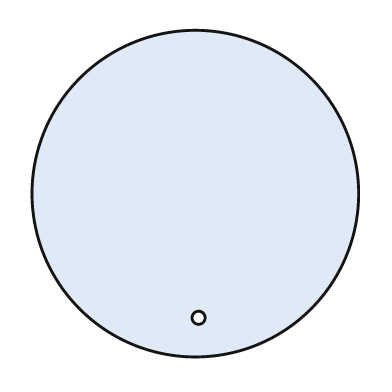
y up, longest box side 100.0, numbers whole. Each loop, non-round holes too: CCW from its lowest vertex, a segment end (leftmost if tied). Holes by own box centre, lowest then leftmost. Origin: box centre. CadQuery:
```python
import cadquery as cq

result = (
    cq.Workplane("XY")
    .moveTo(0.0, 0.0)
    .circle(50.0)
    .moveTo(1.0, -38.0)
    .circle(2.0)
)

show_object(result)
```